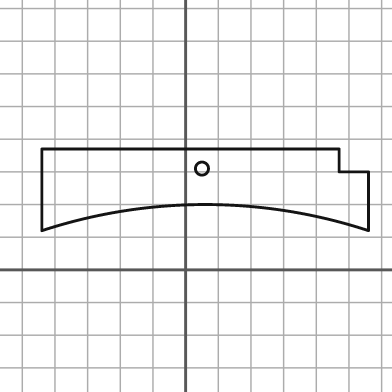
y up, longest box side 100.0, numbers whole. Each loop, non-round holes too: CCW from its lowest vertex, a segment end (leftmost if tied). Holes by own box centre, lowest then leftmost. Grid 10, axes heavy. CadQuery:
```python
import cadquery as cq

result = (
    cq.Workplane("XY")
    .moveTo(-44.0, 12.0)
    .threePointArc((6.0, 20.0), (56.0, 12.0))
    .lineTo(56.0, 30.0)
    .lineTo(47.0, 30.0)
    .lineTo(47.0, 37.0)
    .lineTo(-44.0, 37.0)
    .close()
    .moveTo(5.0, 31.0)
    .circle(2.0)
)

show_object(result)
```